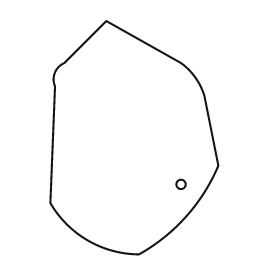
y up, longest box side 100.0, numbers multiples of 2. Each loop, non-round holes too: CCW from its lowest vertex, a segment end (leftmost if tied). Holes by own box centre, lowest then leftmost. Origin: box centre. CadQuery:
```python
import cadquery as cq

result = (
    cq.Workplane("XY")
    .moveTo(2.0, -50.0)
    .threePointArc((22.0, -34.0), (36.0, -12.0))
    .lineTo(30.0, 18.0)
    .threePointArc((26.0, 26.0), (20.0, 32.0))
    .lineTo(-12.0, 50.0)
    .lineTo(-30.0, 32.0)
    .threePointArc((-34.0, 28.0), (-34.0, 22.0))
    .lineTo(-36.0, -28.0)
    .threePointArc((-20.0, -44.0), (2.0, -50.0))
    .close()
    .moveTo(20.0, -20.0)
    .circle(2.0)
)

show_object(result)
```